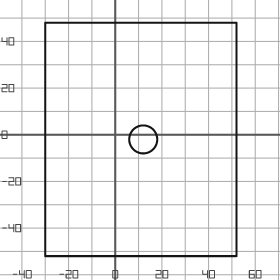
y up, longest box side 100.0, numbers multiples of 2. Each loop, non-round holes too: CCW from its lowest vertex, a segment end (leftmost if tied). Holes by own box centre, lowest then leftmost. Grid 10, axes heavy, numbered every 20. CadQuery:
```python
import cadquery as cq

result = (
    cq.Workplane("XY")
    .moveTo(-30.0, -52.0)
    .lineTo(52.0, -52.0)
    .lineTo(52.0, 48.0)
    .lineTo(-30.0, 48.0)
    .close()
    .moveTo(12.0, -2.0)
    .circle(6.0)
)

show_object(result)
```